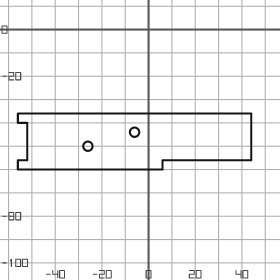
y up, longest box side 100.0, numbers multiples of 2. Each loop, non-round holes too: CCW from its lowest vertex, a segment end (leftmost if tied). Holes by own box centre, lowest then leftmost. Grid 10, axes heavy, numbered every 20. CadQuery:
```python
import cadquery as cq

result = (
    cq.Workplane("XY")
    .moveTo(-56.0, -60.0)
    .lineTo(6.0, -60.0)
    .lineTo(6.0, -56.0)
    .lineTo(44.0, -56.0)
    .lineTo(44.0, -36.0)
    .lineTo(-56.0, -36.0)
    .lineTo(-56.0, -40.0)
    .lineTo(-52.0, -40.0)
    .lineTo(-52.0, -56.0)
    .lineTo(-56.0, -56.0)
    .close()
    .moveTo(-26.0, -50.0)
    .circle(2.0)
    .moveTo(-6.0, -44.0)
    .circle(2.0)
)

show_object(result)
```